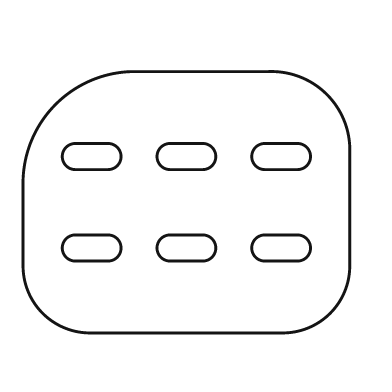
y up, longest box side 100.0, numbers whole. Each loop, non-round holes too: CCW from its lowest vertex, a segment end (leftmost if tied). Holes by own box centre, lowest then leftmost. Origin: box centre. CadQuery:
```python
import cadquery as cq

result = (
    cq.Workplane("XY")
    .moveTo(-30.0, -40.0)
    .lineTo(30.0, -40.0)
    .threePointArc((44.0, -34.0), (50.0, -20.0))
    .lineTo(50.0, 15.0)
    .threePointArc((43.0, 33.0), (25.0, 40.0))
    .lineTo(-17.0, 40.0)
    .threePointArc((-40.0, 30.0), (-50.0, 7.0))
    .lineTo(-50.0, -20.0)
    .threePointArc((-44.0, -34.0), (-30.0, -40.0))
    .close()
    .moveTo(-34.0, -18.0)
    .lineTo(-24.0, -18.0)
    .threePointArc((-20.0, -14.0), (-24.0, -10.0))
    .lineTo(-34.0, -10.0)
    .threePointArc((-38.0, -14.0), (-34.0, -18.0))
    .close()
    .moveTo(-5.0, -18.0)
    .lineTo(5.0, -18.0)
    .threePointArc((9.0, -14.0), (5.0, -10.0))
    .lineTo(-5.0, -10.0)
    .threePointArc((-9.0, -14.0), (-5.0, -18.0))
    .close()
    .moveTo(24.0, -18.0)
    .lineTo(34.0, -18.0)
    .threePointArc((38.0, -14.0), (34.0, -10.0))
    .lineTo(24.0, -10.0)
    .threePointArc((20.0, -14.0), (24.0, -18.0))
    .close()
    .moveTo(-34.0, 10.0)
    .lineTo(-24.0, 10.0)
    .threePointArc((-20.0, 14.0), (-24.0, 18.0))
    .lineTo(-34.0, 18.0)
    .threePointArc((-38.0, 14.0), (-34.0, 10.0))
    .close()
    .moveTo(-5.0, 10.0)
    .lineTo(5.0, 10.0)
    .threePointArc((9.0, 14.0), (5.0, 18.0))
    .lineTo(-5.0, 18.0)
    .threePointArc((-9.0, 14.0), (-5.0, 10.0))
    .close()
    .moveTo(24.0, 10.0)
    .lineTo(34.0, 10.0)
    .threePointArc((38.0, 14.0), (34.0, 18.0))
    .lineTo(24.0, 18.0)
    .threePointArc((20.0, 14.0), (24.0, 10.0))
    .close()
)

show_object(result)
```